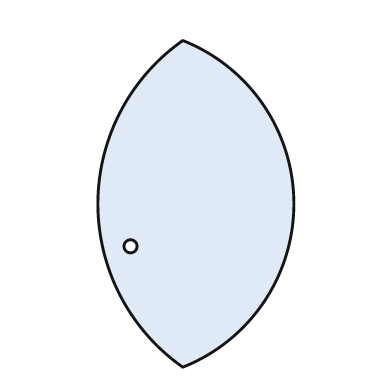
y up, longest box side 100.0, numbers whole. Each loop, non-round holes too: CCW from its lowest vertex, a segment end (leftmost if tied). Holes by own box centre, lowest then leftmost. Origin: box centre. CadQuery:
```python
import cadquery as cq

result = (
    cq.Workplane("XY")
    .moveTo(-4.0, -50.0)
    .threePointArc((30.0, 0.0), (-4.0, 50.0))
    .threePointArc((-30.0, 0.0), (-4.0, -50.0))
    .close()
    .moveTo(-20.0, -13.0)
    .circle(2.0)
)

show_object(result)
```